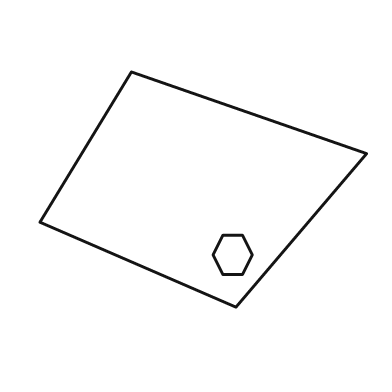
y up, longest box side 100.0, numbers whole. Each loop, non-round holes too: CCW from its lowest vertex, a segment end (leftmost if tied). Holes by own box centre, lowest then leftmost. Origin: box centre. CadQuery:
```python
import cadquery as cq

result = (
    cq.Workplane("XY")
    .moveTo(10.0, -36.0)
    .lineTo(50.0, 11.0)
    .lineTo(-22.0, 36.0)
    .lineTo(-50.0, -10.0)
    .close()
    .moveTo(6.0, -26.0)
    .lineTo(12.0, -26.0)
    .lineTo(15.0, -20.0)
    .lineTo(12.0, -14.0)
    .lineTo(6.0, -14.0)
    .lineTo(3.0, -20.0)
    .close()
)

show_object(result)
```